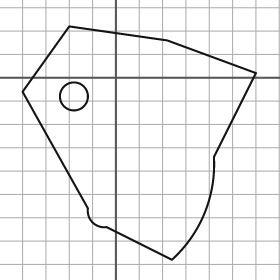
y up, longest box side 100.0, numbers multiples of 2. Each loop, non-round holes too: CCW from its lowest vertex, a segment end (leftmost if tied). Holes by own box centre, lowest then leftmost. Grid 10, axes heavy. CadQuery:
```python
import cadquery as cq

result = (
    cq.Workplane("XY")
    .moveTo(24.0, -78.0)
    .threePointArc((38.0, -58.0), (42.0, -34.0))
    .lineTo(60.0, 2.0)
    .lineTo(22.0, 16.0)
    .lineTo(-20.0, 22.0)
    .lineTo(-40.0, -6.0)
    .lineTo(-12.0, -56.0)
    .threePointArc((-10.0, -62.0), (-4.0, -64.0))
    .close()
    .moveTo(-18.0, -8.0)
    .circle(6.0)
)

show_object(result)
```